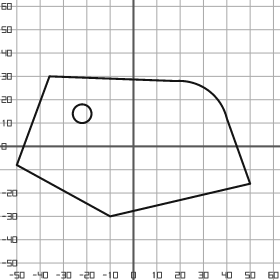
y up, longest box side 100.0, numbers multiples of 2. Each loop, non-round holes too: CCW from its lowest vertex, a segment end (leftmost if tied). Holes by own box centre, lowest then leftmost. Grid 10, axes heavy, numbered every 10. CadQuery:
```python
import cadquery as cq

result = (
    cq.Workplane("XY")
    .moveTo(-10.0, -30.0)
    .lineTo(50.0, -16.0)
    .lineTo(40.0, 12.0)
    .threePointArc((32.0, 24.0), (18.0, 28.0))
    .lineTo(-36.0, 30.0)
    .lineTo(-50.0, -8.0)
    .close()
    .moveTo(-22.0, 14.0)
    .circle(4.0)
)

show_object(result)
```